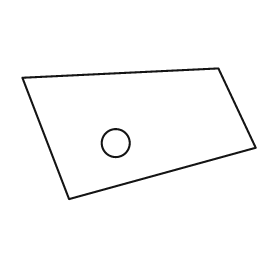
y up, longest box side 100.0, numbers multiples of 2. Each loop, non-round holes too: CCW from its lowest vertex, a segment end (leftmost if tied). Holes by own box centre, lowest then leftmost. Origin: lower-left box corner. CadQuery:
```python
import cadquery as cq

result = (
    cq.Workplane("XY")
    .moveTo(20.0, 0.0)
    .lineTo(100.0, 22.0)
    .lineTo(84.0, 56.0)
    .lineTo(0.0, 52.0)
    .close()
    .moveTo(40.0, 24.0)
    .circle(6.0)
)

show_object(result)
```